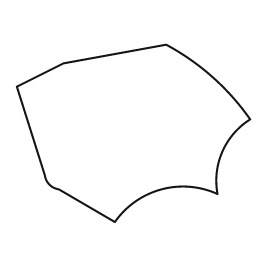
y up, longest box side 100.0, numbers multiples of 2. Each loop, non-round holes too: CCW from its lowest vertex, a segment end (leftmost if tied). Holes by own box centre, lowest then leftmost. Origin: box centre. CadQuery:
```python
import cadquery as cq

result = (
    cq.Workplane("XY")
    .moveTo(-8.0, -38.0)
    .threePointArc((12.0, -24.0), (36.0, -26.0))
    .threePointArc((38.0, -8.0), (50.0, 6.0))
    .threePointArc((34.0, 24.0), (14.0, 38.0))
    .lineTo(-30.0, 30.0)
    .lineTo(-50.0, 20.0)
    .lineTo(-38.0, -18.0)
    .threePointArc((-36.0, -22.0), (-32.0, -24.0))
    .close()
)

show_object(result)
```